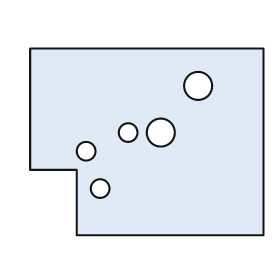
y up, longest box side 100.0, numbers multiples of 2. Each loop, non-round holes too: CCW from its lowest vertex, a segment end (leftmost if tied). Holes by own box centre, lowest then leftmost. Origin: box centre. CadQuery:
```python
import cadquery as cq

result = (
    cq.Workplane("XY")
    .moveTo(-30.0, -40.0)
    .lineTo(50.0, -40.0)
    .lineTo(50.0, 40.0)
    .lineTo(-50.0, 40.0)
    .lineTo(-50.0, -12.0)
    .lineTo(-30.0, -12.0)
    .close()
    .moveTo(-20.0, -20.0)
    .circle(4.0)
    .moveTo(-26.0, -4.0)
    .circle(4.0)
    .moveTo(-8.0, 4.0)
    .circle(4.0)
    .moveTo(6.0, 4.0)
    .circle(6.0)
    .moveTo(22.0, 24.0)
    .circle(6.0)
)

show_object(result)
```